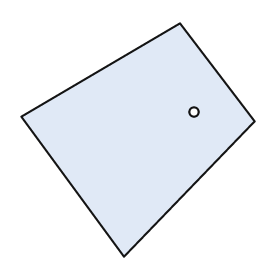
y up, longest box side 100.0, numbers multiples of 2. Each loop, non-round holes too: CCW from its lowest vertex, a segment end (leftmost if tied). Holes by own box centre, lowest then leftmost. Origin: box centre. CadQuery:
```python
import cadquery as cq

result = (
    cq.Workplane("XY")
    .moveTo(-6.0, -50.0)
    .lineTo(50.0, 8.0)
    .lineTo(18.0, 50.0)
    .lineTo(-50.0, 10.0)
    .close()
    .moveTo(24.0, 12.0)
    .circle(2.0)
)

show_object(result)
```